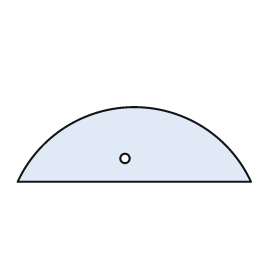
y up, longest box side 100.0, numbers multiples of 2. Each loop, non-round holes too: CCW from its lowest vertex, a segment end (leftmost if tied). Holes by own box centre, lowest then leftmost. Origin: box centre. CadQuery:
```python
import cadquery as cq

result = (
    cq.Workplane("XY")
    .moveTo(-50.0, -16.0)
    .lineTo(50.0, -16.0)
    .threePointArc((0.0, 16.0), (-50.0, -16.0))
    .close()
    .moveTo(-4.0, -6.0)
    .circle(2.0)
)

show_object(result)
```